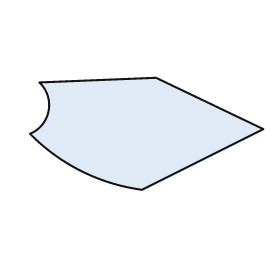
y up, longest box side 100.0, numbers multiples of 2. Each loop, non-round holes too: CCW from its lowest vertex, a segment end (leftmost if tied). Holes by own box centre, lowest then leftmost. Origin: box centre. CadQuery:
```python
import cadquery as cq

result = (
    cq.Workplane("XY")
    .moveTo(-2.0, -24.0)
    .lineTo(50.0, 2.0)
    .lineTo(4.0, 24.0)
    .lineTo(-46.0, 22.0)
    .threePointArc((-42.0, 10.0), (-50.0, 0.0))
    .threePointArc((-28.0, -16.0), (-2.0, -24.0))
    .close()
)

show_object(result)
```